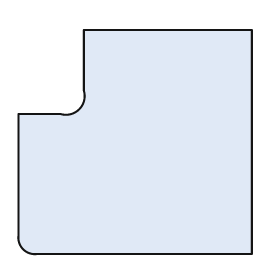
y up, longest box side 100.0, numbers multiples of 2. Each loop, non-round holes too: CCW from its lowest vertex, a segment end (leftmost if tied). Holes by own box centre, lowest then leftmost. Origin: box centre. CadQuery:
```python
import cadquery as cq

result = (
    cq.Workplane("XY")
    .moveTo(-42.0, -48.0)
    .lineTo(50.0, -48.0)
    .lineTo(50.0, 48.0)
    .lineTo(-22.0, 48.0)
    .lineTo(-22.0, 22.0)
    .threePointArc((-24.0, 14.0), (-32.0, 12.0))
    .lineTo(-50.0, 12.0)
    .lineTo(-50.0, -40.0)
    .threePointArc((-48.0, -46.0), (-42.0, -48.0))
    .close()
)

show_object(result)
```